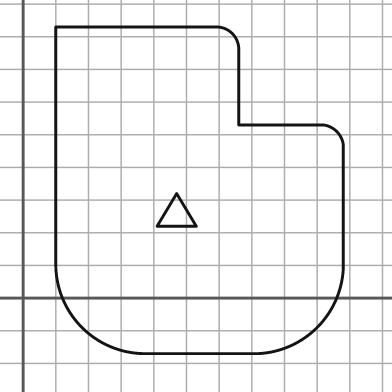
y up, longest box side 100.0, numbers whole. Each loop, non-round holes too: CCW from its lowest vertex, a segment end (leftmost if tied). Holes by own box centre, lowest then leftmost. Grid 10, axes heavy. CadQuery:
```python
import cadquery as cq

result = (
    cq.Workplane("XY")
    .moveTo(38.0, -17.0)
    .lineTo(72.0, -17.0)
    .threePointArc((90.0, -9.0), (98.0, 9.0))
    .lineTo(98.0, 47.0)
    .threePointArc((96.0, 51.0), (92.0, 53.0))
    .lineTo(66.0, 53.0)
    .lineTo(66.0, 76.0)
    .threePointArc((64.0, 81.0), (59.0, 83.0))
    .lineTo(10.0, 83.0)
    .lineTo(10.0, 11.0)
    .threePointArc((18.0, -9.0), (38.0, -17.0))
    .close()
    .moveTo(41.0, 22.0)
    .lineTo(53.0, 22.0)
    .lineTo(47.0, 32.0)
    .close()
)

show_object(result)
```